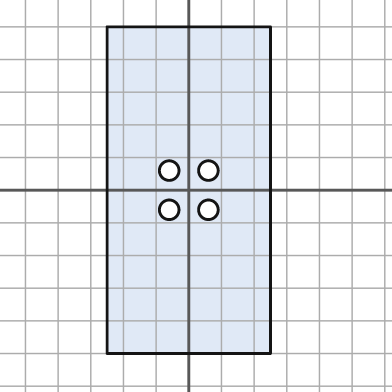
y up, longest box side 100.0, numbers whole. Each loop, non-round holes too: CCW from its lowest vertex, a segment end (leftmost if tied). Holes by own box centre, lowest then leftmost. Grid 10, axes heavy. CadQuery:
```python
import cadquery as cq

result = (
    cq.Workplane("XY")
    .moveTo(-25.0, -50.0)
    .lineTo(25.0, -50.0)
    .lineTo(25.0, 50.0)
    .lineTo(-25.0, 50.0)
    .close()
    .moveTo(-6.0, -6.0)
    .circle(3.0)
    .moveTo(6.0, -6.0)
    .circle(3.0)
    .moveTo(-6.0, 6.0)
    .circle(3.0)
    .moveTo(6.0, 6.0)
    .circle(3.0)
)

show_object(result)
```